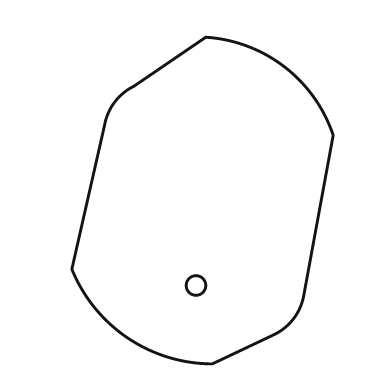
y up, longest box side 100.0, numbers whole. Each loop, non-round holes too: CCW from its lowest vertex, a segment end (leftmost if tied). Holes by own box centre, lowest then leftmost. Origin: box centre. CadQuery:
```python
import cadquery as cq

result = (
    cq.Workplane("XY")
    .moveTo(3.0, -50.0)
    .lineTo(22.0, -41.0)
    .threePointArc((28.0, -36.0), (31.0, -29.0))
    .lineTo(40.0, 20.0)
    .threePointArc((25.0, 41.0), (1.0, 50.0))
    .lineTo(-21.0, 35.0)
    .threePointArc((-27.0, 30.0), (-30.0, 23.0))
    .lineTo(-40.0, -21.0)
    .threePointArc((-23.0, -42.0), (3.0, -50.0))
    .close()
    .moveTo(-2.0, -26.0)
    .circle(3.0)
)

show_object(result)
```